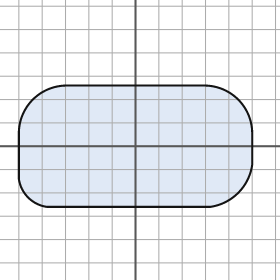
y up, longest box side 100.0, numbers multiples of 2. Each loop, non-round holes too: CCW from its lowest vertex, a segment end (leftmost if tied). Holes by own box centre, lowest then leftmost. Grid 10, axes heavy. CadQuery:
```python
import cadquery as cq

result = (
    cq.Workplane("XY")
    .moveTo(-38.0, -26.0)
    .lineTo(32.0, -26.0)
    .threePointArc((44.0, -20.0), (50.0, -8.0))
    .lineTo(50.0, 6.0)
    .threePointArc((44.0, 20.0), (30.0, 26.0))
    .lineTo(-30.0, 26.0)
    .threePointArc((-44.0, 20.0), (-50.0, 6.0))
    .lineTo(-50.0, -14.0)
    .threePointArc((-46.0, -22.0), (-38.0, -26.0))
    .close()
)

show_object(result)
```